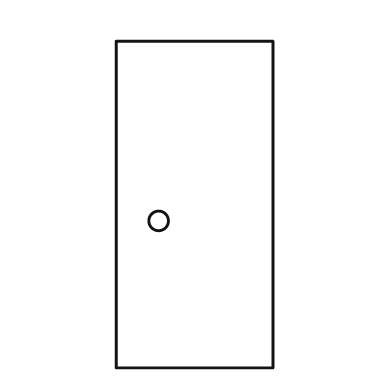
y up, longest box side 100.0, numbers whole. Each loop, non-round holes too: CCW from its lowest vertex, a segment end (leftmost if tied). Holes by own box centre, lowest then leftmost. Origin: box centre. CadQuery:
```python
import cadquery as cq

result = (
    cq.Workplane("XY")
    .moveTo(-24.0, -50.0)
    .lineTo(24.0, -50.0)
    .lineTo(24.0, 50.0)
    .lineTo(-24.0, 50.0)
    .close()
    .moveTo(-11.0, -5.0)
    .circle(3.0)
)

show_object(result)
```